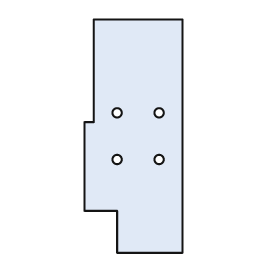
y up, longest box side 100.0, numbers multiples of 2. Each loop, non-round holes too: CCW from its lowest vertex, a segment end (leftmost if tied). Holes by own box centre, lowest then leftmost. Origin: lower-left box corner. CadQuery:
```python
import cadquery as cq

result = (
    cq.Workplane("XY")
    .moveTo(14.0, 0.0)
    .lineTo(42.0, 0.0)
    .lineTo(42.0, 100.0)
    .lineTo(4.0, 100.0)
    .lineTo(4.0, 56.0)
    .lineTo(0.0, 56.0)
    .lineTo(0.0, 18.0)
    .lineTo(14.0, 18.0)
    .close()
    .moveTo(14.0, 40.0)
    .circle(2.0)
    .moveTo(32.0, 40.0)
    .circle(2.0)
    .moveTo(14.0, 60.0)
    .circle(2.0)
    .moveTo(32.0, 60.0)
    .circle(2.0)
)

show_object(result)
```